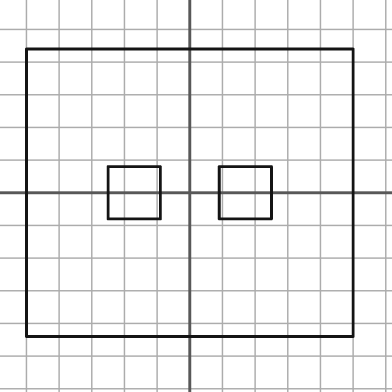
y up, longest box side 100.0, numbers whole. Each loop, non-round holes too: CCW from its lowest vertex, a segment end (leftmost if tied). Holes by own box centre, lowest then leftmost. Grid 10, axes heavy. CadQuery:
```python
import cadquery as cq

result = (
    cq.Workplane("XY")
    .moveTo(-50.0, -44.0)
    .lineTo(50.0, -44.0)
    .lineTo(50.0, 44.0)
    .lineTo(-50.0, 44.0)
    .close()
    .moveTo(-25.0, -8.0)
    .lineTo(-9.0, -8.0)
    .lineTo(-9.0, 8.0)
    .lineTo(-25.0, 8.0)
    .close()
    .moveTo(9.0, -8.0)
    .lineTo(25.0, -8.0)
    .lineTo(25.0, 8.0)
    .lineTo(9.0, 8.0)
    .close()
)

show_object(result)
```